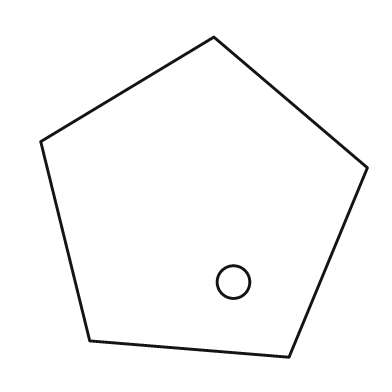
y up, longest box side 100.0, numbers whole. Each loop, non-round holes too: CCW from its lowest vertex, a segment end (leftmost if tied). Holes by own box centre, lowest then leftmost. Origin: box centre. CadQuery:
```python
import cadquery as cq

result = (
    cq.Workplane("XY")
    .moveTo(26.0, -49.0)
    .lineTo(50.0, 9.0)
    .lineTo(3.0, 49.0)
    .lineTo(-50.0, 17.0)
    .lineTo(-35.0, -44.0)
    .close()
    .moveTo(9.0, -26.0)
    .circle(5.0)
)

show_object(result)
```